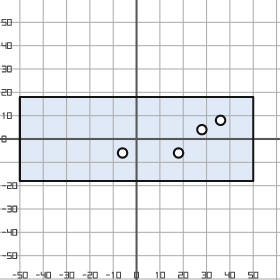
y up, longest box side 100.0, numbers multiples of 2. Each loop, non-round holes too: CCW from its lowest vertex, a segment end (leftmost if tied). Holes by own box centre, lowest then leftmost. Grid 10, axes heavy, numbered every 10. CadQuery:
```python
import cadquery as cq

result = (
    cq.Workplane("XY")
    .moveTo(-50.0, -18.0)
    .lineTo(50.0, -18.0)
    .lineTo(50.0, 18.0)
    .lineTo(-50.0, 18.0)
    .close()
    .moveTo(-6.0, -6.0)
    .circle(2.0)
    .moveTo(18.0, -6.0)
    .circle(2.0)
    .moveTo(28.0, 4.0)
    .circle(2.0)
    .moveTo(36.0, 8.0)
    .circle(2.0)
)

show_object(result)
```